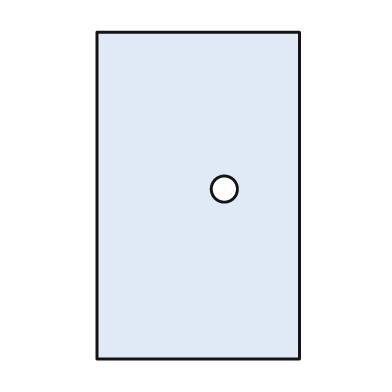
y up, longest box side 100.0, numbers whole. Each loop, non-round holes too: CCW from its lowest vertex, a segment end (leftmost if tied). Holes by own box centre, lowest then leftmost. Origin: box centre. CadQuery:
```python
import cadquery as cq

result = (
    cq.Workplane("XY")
    .moveTo(-31.0, -50.0)
    .lineTo(31.0, -50.0)
    .lineTo(31.0, 50.0)
    .lineTo(-31.0, 50.0)
    .close()
    .moveTo(8.0, 2.0)
    .circle(4.0)
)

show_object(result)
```